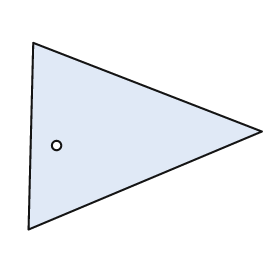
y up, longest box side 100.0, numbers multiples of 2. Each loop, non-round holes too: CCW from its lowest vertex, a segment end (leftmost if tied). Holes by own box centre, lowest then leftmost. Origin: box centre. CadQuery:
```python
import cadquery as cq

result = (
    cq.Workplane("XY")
    .moveTo(-50.0, -40.0)
    .lineTo(50.0, 2.0)
    .lineTo(-48.0, 40.0)
    .close()
    .moveTo(-38.0, -4.0)
    .circle(2.0)
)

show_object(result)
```